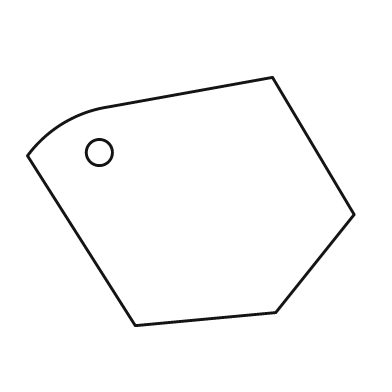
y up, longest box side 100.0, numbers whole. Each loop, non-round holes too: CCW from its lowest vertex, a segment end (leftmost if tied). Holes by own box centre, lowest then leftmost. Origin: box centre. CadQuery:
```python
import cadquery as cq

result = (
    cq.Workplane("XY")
    .moveTo(-17.0, -38.0)
    .lineTo(26.0, -34.0)
    .lineTo(50.0, -4.0)
    .lineTo(25.0, 38.0)
    .lineTo(-25.0, 29.0)
    .threePointArc((-39.0, 24.0), (-50.0, 14.0))
    .close()
    .moveTo(-28.0, 15.0)
    .circle(4.0)
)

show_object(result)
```